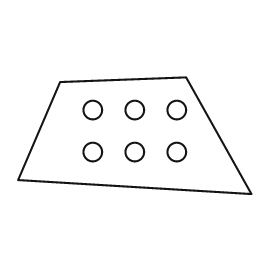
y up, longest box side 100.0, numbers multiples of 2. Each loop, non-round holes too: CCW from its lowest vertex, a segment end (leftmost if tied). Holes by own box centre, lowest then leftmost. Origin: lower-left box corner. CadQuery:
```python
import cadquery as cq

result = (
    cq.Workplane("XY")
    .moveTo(100.0, 0.0)
    .lineTo(72.0, 50.0)
    .lineTo(18.0, 48.0)
    .lineTo(0.0, 6.0)
    .close()
    .moveTo(32.0, 18.0)
    .circle(4.0)
    .moveTo(50.0, 18.0)
    .circle(4.0)
    .moveTo(68.0, 18.0)
    .circle(4.0)
    .moveTo(32.0, 36.0)
    .circle(4.0)
    .moveTo(50.0, 36.0)
    .circle(4.0)
    .moveTo(68.0, 36.0)
    .circle(4.0)
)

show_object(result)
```